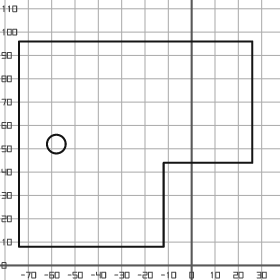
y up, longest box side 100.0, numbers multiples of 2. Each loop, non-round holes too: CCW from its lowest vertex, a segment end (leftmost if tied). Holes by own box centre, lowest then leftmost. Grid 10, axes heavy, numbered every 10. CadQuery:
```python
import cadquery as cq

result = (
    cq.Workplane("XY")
    .moveTo(-74.0, 8.0)
    .lineTo(-12.0, 8.0)
    .lineTo(-12.0, 44.0)
    .lineTo(26.0, 44.0)
    .lineTo(26.0, 96.0)
    .lineTo(-74.0, 96.0)
    .close()
    .moveTo(-58.0, 52.0)
    .circle(4.0)
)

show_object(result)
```